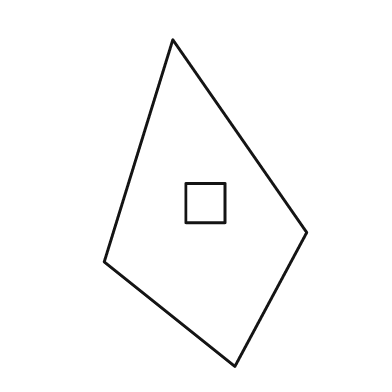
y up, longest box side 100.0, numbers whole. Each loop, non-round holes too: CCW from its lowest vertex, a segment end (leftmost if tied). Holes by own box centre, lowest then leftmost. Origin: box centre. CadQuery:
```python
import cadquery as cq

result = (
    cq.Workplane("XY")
    .moveTo(9.0, -50.0)
    .lineTo(31.0, -9.0)
    .lineTo(-10.0, 50.0)
    .lineTo(-31.0, -18.0)
    .close()
    .moveTo(-6.0, -6.0)
    .lineTo(6.0, -6.0)
    .lineTo(6.0, 6.0)
    .lineTo(-6.0, 6.0)
    .close()
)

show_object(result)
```